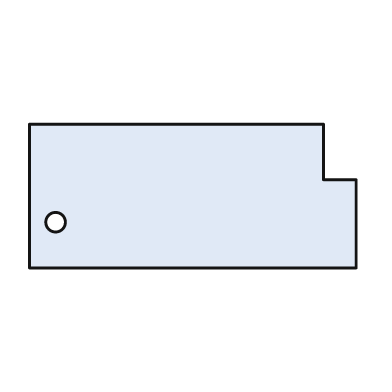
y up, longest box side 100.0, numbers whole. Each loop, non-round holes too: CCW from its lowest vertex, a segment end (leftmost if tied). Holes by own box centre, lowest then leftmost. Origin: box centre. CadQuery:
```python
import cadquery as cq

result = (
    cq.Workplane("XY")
    .moveTo(-50.0, -22.0)
    .lineTo(50.0, -22.0)
    .lineTo(50.0, 5.0)
    .lineTo(40.0, 5.0)
    .lineTo(40.0, 22.0)
    .lineTo(-50.0, 22.0)
    .close()
    .moveTo(-42.0, -8.0)
    .circle(3.0)
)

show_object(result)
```